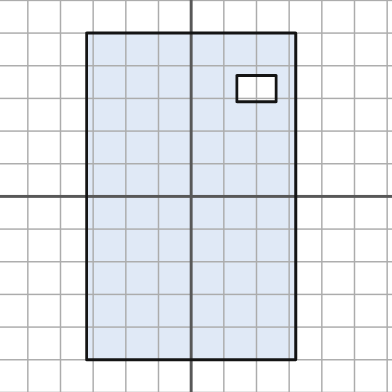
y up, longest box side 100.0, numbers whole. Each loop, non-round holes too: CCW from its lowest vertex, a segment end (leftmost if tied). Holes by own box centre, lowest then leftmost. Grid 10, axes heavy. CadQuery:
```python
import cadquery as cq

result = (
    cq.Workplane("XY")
    .moveTo(-32.0, -50.0)
    .lineTo(32.0, -50.0)
    .lineTo(32.0, 50.0)
    .lineTo(-32.0, 50.0)
    .close()
    .moveTo(14.0, 29.0)
    .lineTo(26.0, 29.0)
    .lineTo(26.0, 37.0)
    .lineTo(14.0, 37.0)
    .close()
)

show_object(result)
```